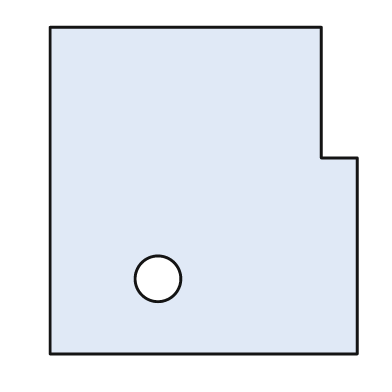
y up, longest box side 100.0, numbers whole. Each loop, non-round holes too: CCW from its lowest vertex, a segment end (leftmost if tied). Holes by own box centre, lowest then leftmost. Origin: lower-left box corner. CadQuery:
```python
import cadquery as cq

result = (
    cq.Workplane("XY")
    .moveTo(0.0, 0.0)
    .lineTo(94.0, 0.0)
    .lineTo(94.0, 60.0)
    .lineTo(83.0, 60.0)
    .lineTo(83.0, 100.0)
    .lineTo(0.0, 100.0)
    .close()
    .moveTo(33.0, 23.0)
    .circle(7.0)
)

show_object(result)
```